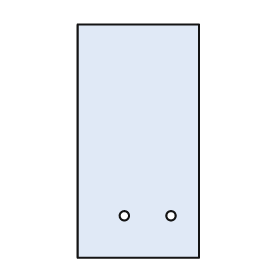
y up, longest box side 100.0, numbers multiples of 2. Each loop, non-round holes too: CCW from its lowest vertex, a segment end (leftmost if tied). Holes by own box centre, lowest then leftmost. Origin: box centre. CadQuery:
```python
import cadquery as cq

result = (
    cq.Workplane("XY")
    .moveTo(-26.0, -50.0)
    .lineTo(26.0, -50.0)
    .lineTo(26.0, 50.0)
    .lineTo(-26.0, 50.0)
    .close()
    .moveTo(-6.0, -32.0)
    .circle(2.0)
    .moveTo(14.0, -32.0)
    .circle(2.0)
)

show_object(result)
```